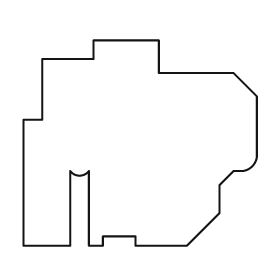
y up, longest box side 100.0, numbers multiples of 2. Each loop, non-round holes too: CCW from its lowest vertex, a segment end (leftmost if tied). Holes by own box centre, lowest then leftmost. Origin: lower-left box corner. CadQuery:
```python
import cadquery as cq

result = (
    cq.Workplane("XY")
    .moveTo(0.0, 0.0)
    .lineTo(20.0, 0.0)
    .lineTo(20.0, 32.0)
    .threePointArc((24.0, 30.0), (28.0, 32.0))
    .lineTo(28.0, 0.0)
    .lineTo(34.0, 0.0)
    .lineTo(34.0, 4.0)
    .lineTo(48.0, 4.0)
    .lineTo(48.0, 0.0)
    .lineTo(70.0, 0.0)
    .lineTo(84.0, 14.0)
    .lineTo(84.0, 26.0)
    .lineTo(90.0, 32.0)
    .lineTo(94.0, 32.0)
    .threePointArc((98.0, 34.0), (100.0, 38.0))
    .lineTo(100.0, 64.0)
    .lineTo(90.0, 74.0)
    .lineTo(58.0, 74.0)
    .lineTo(58.0, 88.0)
    .lineTo(30.0, 88.0)
    .lineTo(30.0, 80.0)
    .lineTo(8.0, 80.0)
    .lineTo(8.0, 54.0)
    .lineTo(0.0, 54.0)
    .close()
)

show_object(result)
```